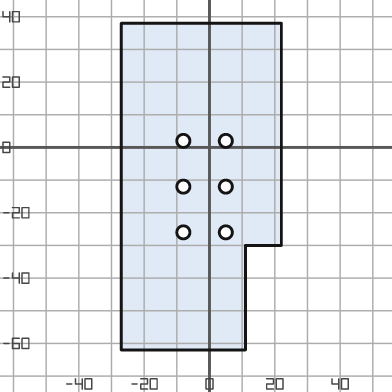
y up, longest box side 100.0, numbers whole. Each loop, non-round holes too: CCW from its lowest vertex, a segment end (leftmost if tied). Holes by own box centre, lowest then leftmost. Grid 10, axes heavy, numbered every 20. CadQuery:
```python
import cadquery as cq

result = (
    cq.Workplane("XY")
    .moveTo(-27.0, -62.0)
    .lineTo(11.0, -62.0)
    .lineTo(11.0, -30.0)
    .lineTo(22.0, -30.0)
    .lineTo(22.0, 38.0)
    .lineTo(-27.0, 38.0)
    .close()
    .moveTo(-8.0, -26.0)
    .circle(2.0)
    .moveTo(5.0, -26.0)
    .circle(2.0)
    .moveTo(-8.0, -12.0)
    .circle(2.0)
    .moveTo(5.0, -12.0)
    .circle(2.0)
    .moveTo(-8.0, 2.0)
    .circle(2.0)
    .moveTo(5.0, 2.0)
    .circle(2.0)
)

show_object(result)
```